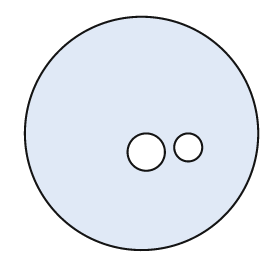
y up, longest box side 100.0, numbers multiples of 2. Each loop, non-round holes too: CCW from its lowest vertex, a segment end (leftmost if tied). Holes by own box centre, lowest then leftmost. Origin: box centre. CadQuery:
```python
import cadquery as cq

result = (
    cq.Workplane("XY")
    .moveTo(0.0, 0.0)
    .circle(50.0)
    .moveTo(2.0, -8.0)
    .circle(8.0)
    .moveTo(20.0, -6.0)
    .circle(6.0)
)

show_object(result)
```